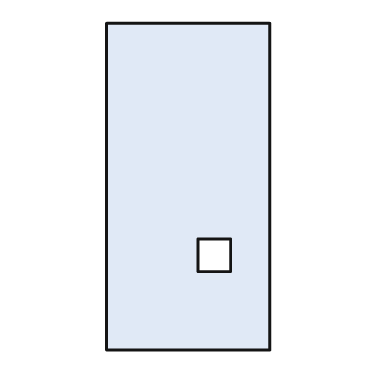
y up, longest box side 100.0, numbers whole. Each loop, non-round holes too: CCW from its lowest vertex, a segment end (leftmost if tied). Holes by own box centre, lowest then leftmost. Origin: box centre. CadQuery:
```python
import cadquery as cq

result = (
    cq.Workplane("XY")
    .moveTo(-25.0, -50.0)
    .lineTo(25.0, -50.0)
    .lineTo(25.0, 50.0)
    .lineTo(-25.0, 50.0)
    .close()
    .moveTo(3.0, -26.0)
    .lineTo(13.0, -26.0)
    .lineTo(13.0, -16.0)
    .lineTo(3.0, -16.0)
    .close()
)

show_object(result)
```